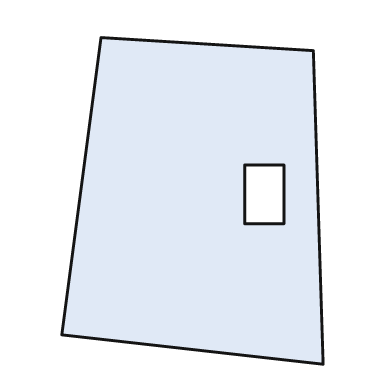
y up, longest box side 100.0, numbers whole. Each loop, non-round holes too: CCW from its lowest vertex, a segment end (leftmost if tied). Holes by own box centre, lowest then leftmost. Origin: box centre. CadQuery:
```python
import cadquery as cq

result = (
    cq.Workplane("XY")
    .moveTo(40.0, -50.0)
    .lineTo(37.0, 46.0)
    .lineTo(-28.0, 50.0)
    .lineTo(-40.0, -41.0)
    .close()
    .moveTo(16.0, -7.0)
    .lineTo(28.0, -7.0)
    .lineTo(28.0, 11.0)
    .lineTo(16.0, 11.0)
    .close()
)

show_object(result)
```